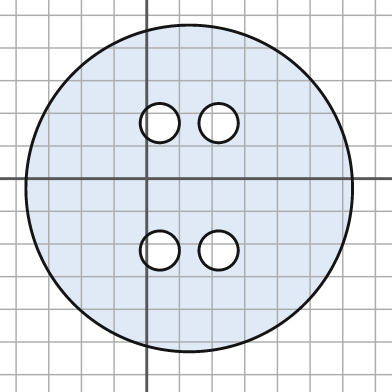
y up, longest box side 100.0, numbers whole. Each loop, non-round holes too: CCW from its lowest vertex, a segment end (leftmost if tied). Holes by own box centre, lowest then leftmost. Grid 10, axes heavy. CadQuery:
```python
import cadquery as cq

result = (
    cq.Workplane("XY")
    .moveTo(13.0, -3.0)
    .circle(50.0)
    .moveTo(4.0, -22.0)
    .circle(6.0)
    .moveTo(22.0, -22.0)
    .circle(6.0)
    .moveTo(4.0, 17.0)
    .circle(6.0)
    .moveTo(22.0, 17.0)
    .circle(6.0)
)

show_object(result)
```